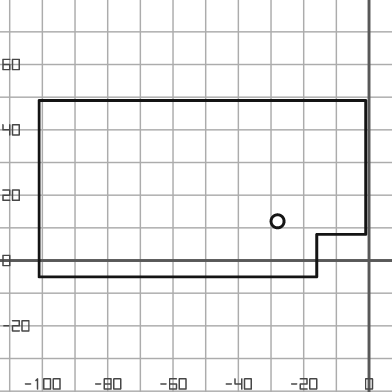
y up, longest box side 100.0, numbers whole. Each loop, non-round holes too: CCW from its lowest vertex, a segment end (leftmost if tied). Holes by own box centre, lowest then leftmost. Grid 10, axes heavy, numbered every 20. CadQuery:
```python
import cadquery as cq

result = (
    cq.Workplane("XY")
    .moveTo(-101.0, -5.0)
    .lineTo(-16.0, -5.0)
    .lineTo(-16.0, 8.0)
    .lineTo(-1.0, 8.0)
    .lineTo(-1.0, 49.0)
    .lineTo(-101.0, 49.0)
    .close()
    .moveTo(-28.0, 12.0)
    .circle(2.0)
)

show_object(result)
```